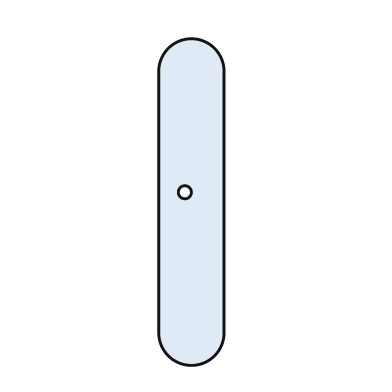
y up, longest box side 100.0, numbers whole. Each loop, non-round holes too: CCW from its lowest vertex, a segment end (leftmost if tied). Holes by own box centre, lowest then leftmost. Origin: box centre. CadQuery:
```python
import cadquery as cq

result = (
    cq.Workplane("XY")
    .moveTo(-10.0, -40.0)
    .threePointArc((0.0, -50.0), (10.0, -40.0))
    .lineTo(10.0, 40.0)
    .threePointArc((0.0, 50.0), (-10.0, 40.0))
    .close()
    .moveTo(-2.0, 3.0)
    .circle(2.0)
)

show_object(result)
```